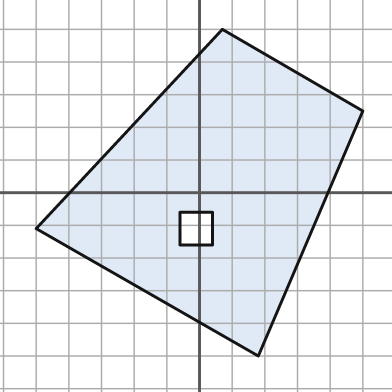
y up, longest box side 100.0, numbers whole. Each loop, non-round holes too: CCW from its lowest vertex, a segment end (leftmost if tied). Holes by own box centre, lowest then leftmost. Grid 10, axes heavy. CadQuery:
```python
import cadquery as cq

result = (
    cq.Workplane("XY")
    .moveTo(18.0, -50.0)
    .lineTo(50.0, 25.0)
    .lineTo(7.0, 50.0)
    .lineTo(-50.0, -11.0)
    .close()
    .moveTo(-6.0, -16.0)
    .lineTo(4.0, -16.0)
    .lineTo(4.0, -6.0)
    .lineTo(-6.0, -6.0)
    .close()
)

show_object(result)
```